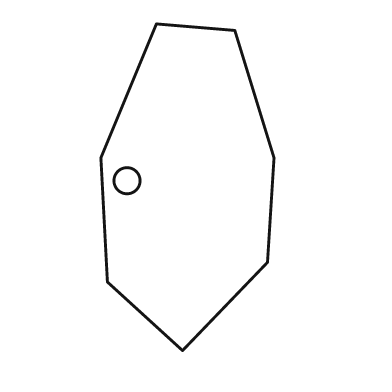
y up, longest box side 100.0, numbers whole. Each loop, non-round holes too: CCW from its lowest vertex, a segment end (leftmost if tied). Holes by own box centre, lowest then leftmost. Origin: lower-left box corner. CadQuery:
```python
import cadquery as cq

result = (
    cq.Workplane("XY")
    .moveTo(25.0, 0.0)
    .lineTo(51.0, 27.0)
    .lineTo(53.0, 59.0)
    .lineTo(41.0, 98.0)
    .lineTo(17.0, 100.0)
    .lineTo(0.0, 59.0)
    .lineTo(2.0, 21.0)
    .close()
    .moveTo(8.0, 52.0)
    .circle(4.0)
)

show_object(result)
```